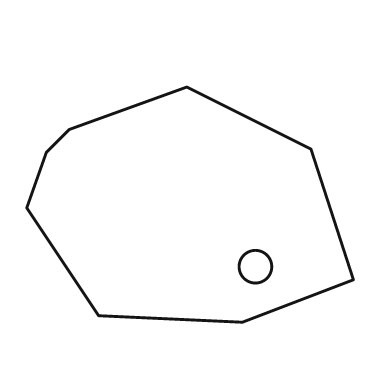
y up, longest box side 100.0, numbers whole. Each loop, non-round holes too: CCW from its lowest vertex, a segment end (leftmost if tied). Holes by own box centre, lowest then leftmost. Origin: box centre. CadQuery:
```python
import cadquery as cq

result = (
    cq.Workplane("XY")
    .moveTo(16.0, -36.0)
    .lineTo(50.0, -23.0)
    .lineTo(37.0, 17.0)
    .lineTo(-1.0, 36.0)
    .lineTo(-37.0, 23.0)
    .lineTo(-44.0, 16.0)
    .lineTo(-50.0, -1.0)
    .lineTo(-28.0, -34.0)
    .close()
    .moveTo(20.0, -19.0)
    .circle(5.0)
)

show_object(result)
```